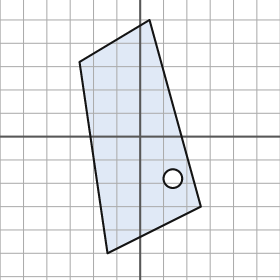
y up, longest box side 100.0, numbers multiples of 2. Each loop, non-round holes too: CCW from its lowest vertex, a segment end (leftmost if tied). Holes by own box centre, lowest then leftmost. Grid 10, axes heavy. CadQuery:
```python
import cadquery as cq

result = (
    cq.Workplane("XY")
    .moveTo(-14.0, -50.0)
    .lineTo(26.0, -30.0)
    .lineTo(4.0, 50.0)
    .lineTo(-26.0, 32.0)
    .close()
    .moveTo(14.0, -18.0)
    .circle(4.0)
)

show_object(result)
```